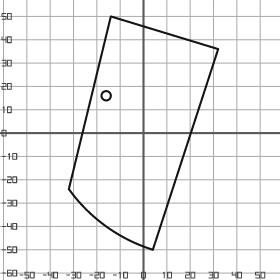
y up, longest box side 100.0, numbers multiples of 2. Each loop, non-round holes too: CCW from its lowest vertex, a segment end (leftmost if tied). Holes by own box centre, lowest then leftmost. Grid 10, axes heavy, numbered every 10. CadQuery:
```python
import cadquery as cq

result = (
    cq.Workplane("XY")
    .moveTo(4.0, -50.0)
    .lineTo(32.0, 36.0)
    .lineTo(-14.0, 50.0)
    .lineTo(-32.0, -24.0)
    .threePointArc((-16.0, -40.0), (4.0, -50.0))
    .close()
    .moveTo(-16.0, 16.0)
    .circle(2.0)
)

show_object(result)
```